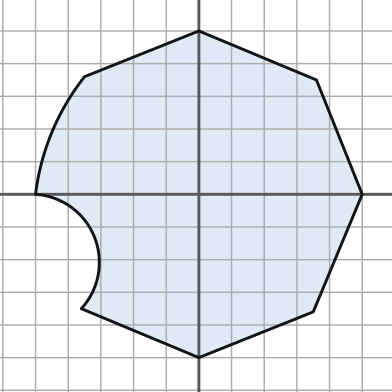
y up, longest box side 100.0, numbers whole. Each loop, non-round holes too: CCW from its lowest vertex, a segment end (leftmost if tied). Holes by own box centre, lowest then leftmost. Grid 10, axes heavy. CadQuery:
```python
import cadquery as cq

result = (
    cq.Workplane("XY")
    .moveTo(0.0, -50.0)
    .lineTo(35.0, -36.0)
    .lineTo(50.0, 0.0)
    .lineTo(36.0, 35.0)
    .lineTo(0.0, 50.0)
    .lineTo(-35.0, 36.0)
    .threePointArc((-45.0, 19.0), (-50.0, 0.0))
    .threePointArc((-32.0, -13.0), (-36.0, -35.0))
    .close()
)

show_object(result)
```